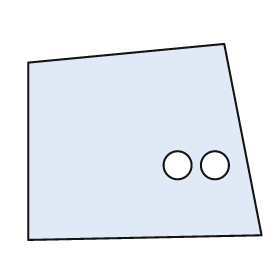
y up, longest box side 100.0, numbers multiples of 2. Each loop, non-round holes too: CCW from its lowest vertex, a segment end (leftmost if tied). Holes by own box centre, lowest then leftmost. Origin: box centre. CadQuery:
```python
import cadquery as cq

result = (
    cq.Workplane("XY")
    .moveTo(-50.0, -42.0)
    .lineTo(50.0, -40.0)
    .lineTo(34.0, 42.0)
    .lineTo(-50.0, 34.0)
    .close()
    .moveTo(14.0, -10.0)
    .circle(6.0)
    .moveTo(30.0, -10.0)
    .circle(6.0)
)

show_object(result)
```